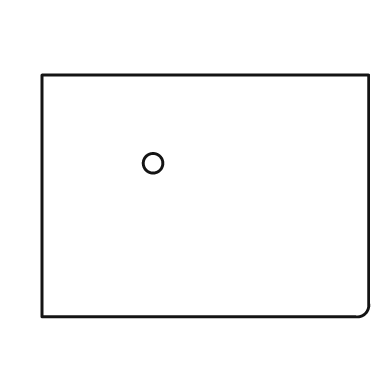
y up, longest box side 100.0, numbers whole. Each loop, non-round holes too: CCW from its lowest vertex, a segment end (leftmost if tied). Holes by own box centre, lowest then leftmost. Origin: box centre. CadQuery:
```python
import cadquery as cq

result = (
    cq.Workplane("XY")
    .moveTo(-50.0, -37.0)
    .lineTo(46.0, -37.0)
    .threePointArc((49.0, -36.0), (50.0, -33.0))
    .lineTo(50.0, 37.0)
    .lineTo(-50.0, 37.0)
    .close()
    .moveTo(-16.0, 10.0)
    .circle(3.0)
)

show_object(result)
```